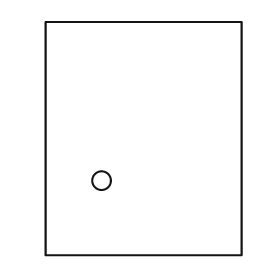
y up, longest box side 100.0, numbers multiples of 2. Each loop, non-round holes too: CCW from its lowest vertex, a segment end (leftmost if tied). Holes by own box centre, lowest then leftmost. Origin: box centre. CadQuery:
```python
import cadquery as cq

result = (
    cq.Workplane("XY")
    .moveTo(-42.0, -50.0)
    .lineTo(42.0, -50.0)
    .lineTo(42.0, 50.0)
    .lineTo(-42.0, 50.0)
    .close()
    .moveTo(-18.0, -18.0)
    .circle(4.0)
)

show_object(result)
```